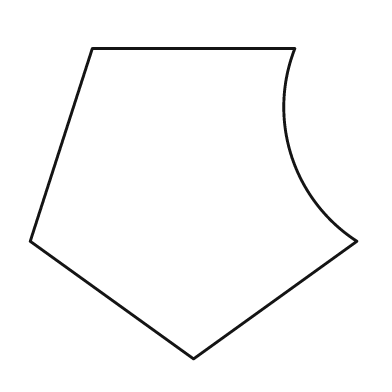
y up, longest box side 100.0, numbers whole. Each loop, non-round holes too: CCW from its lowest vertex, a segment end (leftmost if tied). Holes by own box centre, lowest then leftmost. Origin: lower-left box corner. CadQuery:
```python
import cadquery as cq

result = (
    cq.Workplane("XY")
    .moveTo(50.0, 0.0)
    .lineTo(100.0, 36.0)
    .threePointArc((80.0, 62.0), (81.0, 95.0))
    .lineTo(19.0, 95.0)
    .lineTo(0.0, 36.0)
    .close()
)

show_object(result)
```